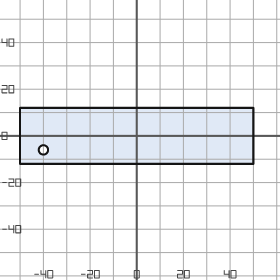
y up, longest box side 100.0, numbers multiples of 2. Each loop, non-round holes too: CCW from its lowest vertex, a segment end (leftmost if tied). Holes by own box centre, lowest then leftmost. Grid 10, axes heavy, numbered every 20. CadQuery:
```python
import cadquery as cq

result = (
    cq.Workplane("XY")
    .moveTo(-50.0, -12.0)
    .lineTo(50.0, -12.0)
    .lineTo(50.0, 12.0)
    .lineTo(-50.0, 12.0)
    .close()
    .moveTo(-40.0, -6.0)
    .circle(2.0)
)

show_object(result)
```